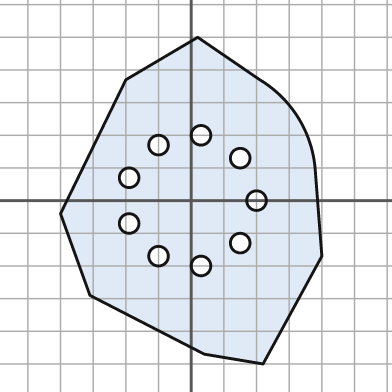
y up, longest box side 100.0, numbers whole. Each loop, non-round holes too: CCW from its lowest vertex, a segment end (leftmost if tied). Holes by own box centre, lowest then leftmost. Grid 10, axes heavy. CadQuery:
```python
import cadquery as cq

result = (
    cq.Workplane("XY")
    .moveTo(22.0, -50.0)
    .lineTo(40.0, -17.0)
    .lineTo(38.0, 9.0)
    .threePointArc((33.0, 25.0), (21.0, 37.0))
    .lineTo(2.0, 50.0)
    .lineTo(-20.0, 37.0)
    .lineTo(-40.0, -4.0)
    .lineTo(-31.0, -29.0)
    .lineTo(4.0, -47.0)
    .close()
    .moveTo(3.0, -20.0)
    .circle(3.0)
    .moveTo(-10.0, -17.0)
    .circle(3.0)
    .moveTo(15.0, -13.0)
    .circle(3.0)
    .moveTo(-19.0, -7.0)
    .circle(3.0)
    .moveTo(20.0, 0.0)
    .circle(3.0)
    .moveTo(-19.0, 7.0)
    .circle(3.0)
    .moveTo(15.0, 13.0)
    .circle(3.0)
    .moveTo(-10.0, 17.0)
    .circle(3.0)
    .moveTo(3.0, 20.0)
    .circle(3.0)
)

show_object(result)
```